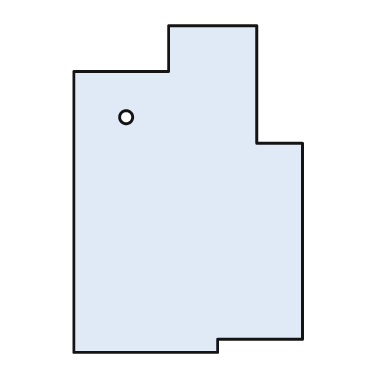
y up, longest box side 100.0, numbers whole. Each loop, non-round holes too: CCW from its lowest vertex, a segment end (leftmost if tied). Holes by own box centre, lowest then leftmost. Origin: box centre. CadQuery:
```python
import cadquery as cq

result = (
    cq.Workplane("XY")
    .moveTo(-35.0, -50.0)
    .lineTo(9.0, -50.0)
    .lineTo(9.0, -46.0)
    .lineTo(35.0, -46.0)
    .lineTo(35.0, 14.0)
    .lineTo(21.0, 14.0)
    .lineTo(21.0, 50.0)
    .lineTo(-6.0, 50.0)
    .lineTo(-6.0, 36.0)
    .lineTo(-35.0, 36.0)
    .close()
    .moveTo(-19.0, 22.0)
    .circle(2.0)
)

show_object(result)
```